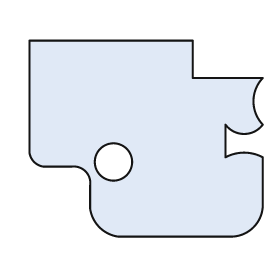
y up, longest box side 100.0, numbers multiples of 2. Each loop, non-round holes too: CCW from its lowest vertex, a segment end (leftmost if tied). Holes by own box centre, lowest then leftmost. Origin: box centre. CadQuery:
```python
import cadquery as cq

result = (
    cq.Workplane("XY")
    .moveTo(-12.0, -42.0)
    .lineTo(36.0, -42.0)
    .threePointArc((46.0, -38.0), (50.0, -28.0))
    .lineTo(50.0, -8.0)
    .threePointArc((42.0, -6.0), (34.0, -8.0))
    .lineTo(34.0, 6.0)
    .threePointArc((42.0, 2.0), (50.0, 6.0))
    .threePointArc((46.0, 16.0), (50.0, 26.0))
    .lineTo(20.0, 26.0)
    .lineTo(20.0, 42.0)
    .lineTo(-50.0, 42.0)
    .lineTo(-50.0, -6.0)
    .threePointArc((-48.0, -10.0), (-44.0, -12.0))
    .lineTo(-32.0, -12.0)
    .threePointArc((-26.0, -14.0), (-24.0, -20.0))
    .lineTo(-24.0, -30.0)
    .threePointArc((-20.0, -38.0), (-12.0, -42.0))
    .close()
    .moveTo(-14.0, -10.0)
    .circle(8.0)
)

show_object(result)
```